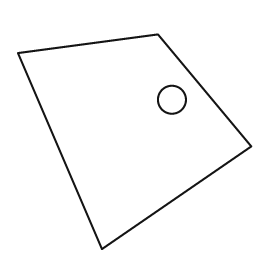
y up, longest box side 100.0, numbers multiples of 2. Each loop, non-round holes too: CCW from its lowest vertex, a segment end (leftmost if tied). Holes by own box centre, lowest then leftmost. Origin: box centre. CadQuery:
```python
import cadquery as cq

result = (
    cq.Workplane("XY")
    .moveTo(-14.0, -46.0)
    .lineTo(50.0, -2.0)
    .lineTo(10.0, 46.0)
    .lineTo(-50.0, 38.0)
    .close()
    .moveTo(16.0, 18.0)
    .circle(6.0)
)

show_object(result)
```